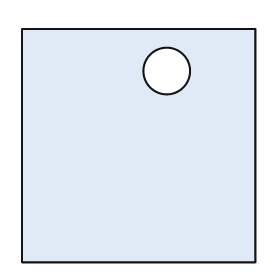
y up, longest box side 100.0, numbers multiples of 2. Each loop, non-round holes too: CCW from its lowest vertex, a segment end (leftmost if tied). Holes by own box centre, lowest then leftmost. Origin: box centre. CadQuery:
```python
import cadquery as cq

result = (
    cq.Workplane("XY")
    .moveTo(-50.0, -50.0)
    .lineTo(50.0, -50.0)
    .lineTo(50.0, 50.0)
    .lineTo(-50.0, 50.0)
    .close()
    .moveTo(12.0, 32.0)
    .circle(10.0)
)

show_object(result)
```